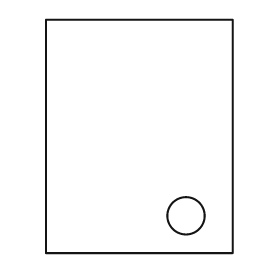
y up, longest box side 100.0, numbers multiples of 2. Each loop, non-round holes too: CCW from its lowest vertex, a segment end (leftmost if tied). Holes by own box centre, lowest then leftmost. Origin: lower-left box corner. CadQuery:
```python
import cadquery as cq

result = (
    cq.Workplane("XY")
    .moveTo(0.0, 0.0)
    .lineTo(80.0, 0.0)
    .lineTo(80.0, 100.0)
    .lineTo(0.0, 100.0)
    .close()
    .moveTo(60.0, 16.0)
    .circle(8.0)
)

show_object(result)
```